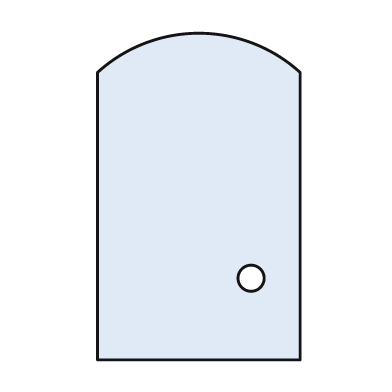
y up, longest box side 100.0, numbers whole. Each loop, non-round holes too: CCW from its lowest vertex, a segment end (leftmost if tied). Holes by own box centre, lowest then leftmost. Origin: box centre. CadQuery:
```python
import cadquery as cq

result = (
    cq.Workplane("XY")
    .moveTo(-31.0, -50.0)
    .lineTo(31.0, -50.0)
    .lineTo(31.0, 38.0)
    .threePointArc((0.0, 50.0), (-31.0, 38.0))
    .close()
    .moveTo(16.0, -25.0)
    .circle(4.0)
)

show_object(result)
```